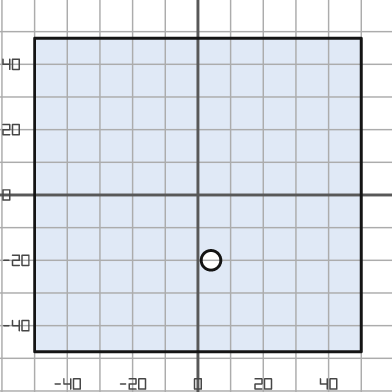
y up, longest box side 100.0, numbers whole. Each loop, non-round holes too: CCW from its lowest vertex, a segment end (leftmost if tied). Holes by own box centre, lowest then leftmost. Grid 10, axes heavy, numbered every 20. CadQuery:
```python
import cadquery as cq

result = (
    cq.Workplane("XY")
    .moveTo(-50.0, -48.0)
    .lineTo(50.0, -48.0)
    .lineTo(50.0, 48.0)
    .lineTo(-50.0, 48.0)
    .close()
    .moveTo(4.0, -20.0)
    .circle(3.0)
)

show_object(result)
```